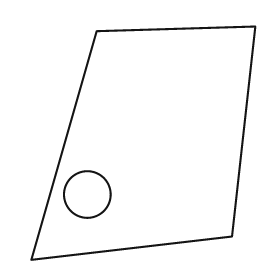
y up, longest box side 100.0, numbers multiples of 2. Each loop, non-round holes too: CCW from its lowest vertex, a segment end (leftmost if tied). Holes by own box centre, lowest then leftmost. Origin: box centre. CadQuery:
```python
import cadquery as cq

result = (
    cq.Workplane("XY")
    .moveTo(-48.0, -50.0)
    .lineTo(38.0, -40.0)
    .lineTo(48.0, 50.0)
    .lineTo(-20.0, 48.0)
    .close()
    .moveTo(-24.0, -22.0)
    .circle(10.0)
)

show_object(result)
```